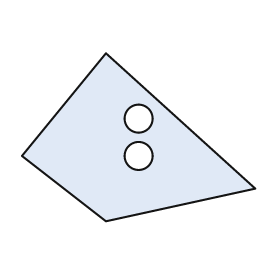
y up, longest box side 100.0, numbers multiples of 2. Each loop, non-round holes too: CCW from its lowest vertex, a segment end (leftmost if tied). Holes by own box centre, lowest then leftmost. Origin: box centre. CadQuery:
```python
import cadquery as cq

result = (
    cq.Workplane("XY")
    .moveTo(-14.0, -36.0)
    .lineTo(50.0, -22.0)
    .lineTo(-14.0, 36.0)
    .lineTo(-50.0, -8.0)
    .close()
    .moveTo(0.0, -8.0)
    .circle(6.0)
    .moveTo(0.0, 8.0)
    .circle(6.0)
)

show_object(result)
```